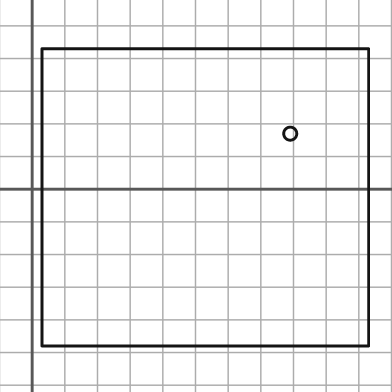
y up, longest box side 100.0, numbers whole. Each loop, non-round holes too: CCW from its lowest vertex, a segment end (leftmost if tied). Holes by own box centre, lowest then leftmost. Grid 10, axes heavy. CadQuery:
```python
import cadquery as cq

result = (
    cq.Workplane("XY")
    .moveTo(3.0, -48.0)
    .lineTo(103.0, -48.0)
    .lineTo(103.0, 43.0)
    .lineTo(3.0, 43.0)
    .close()
    .moveTo(79.0, 17.0)
    .circle(2.0)
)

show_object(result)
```